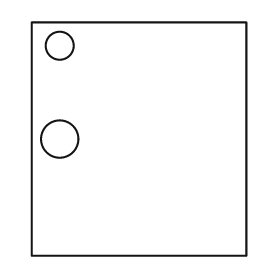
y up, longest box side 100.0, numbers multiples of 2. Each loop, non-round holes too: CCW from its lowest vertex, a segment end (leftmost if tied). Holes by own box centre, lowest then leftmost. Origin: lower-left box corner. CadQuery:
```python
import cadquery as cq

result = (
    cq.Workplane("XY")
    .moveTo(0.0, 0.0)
    .lineTo(92.0, 0.0)
    .lineTo(92.0, 100.0)
    .lineTo(0.0, 100.0)
    .close()
    .moveTo(12.0, 50.0)
    .circle(8.0)
    .moveTo(12.0, 90.0)
    .circle(6.0)
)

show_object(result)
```